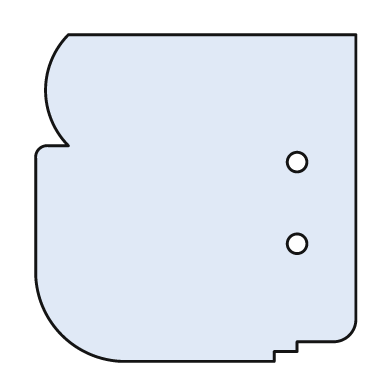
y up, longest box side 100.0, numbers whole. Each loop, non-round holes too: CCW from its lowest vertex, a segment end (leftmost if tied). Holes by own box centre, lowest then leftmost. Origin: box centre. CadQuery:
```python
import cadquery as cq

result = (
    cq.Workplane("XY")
    .moveTo(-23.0, -50.0)
    .lineTo(24.0, -50.0)
    .lineTo(24.0, -47.0)
    .lineTo(31.0, -47.0)
    .lineTo(31.0, -44.0)
    .lineTo(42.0, -44.0)
    .threePointArc((47.0, -42.0), (49.0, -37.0))
    .lineTo(49.0, 50.0)
    .lineTo(-39.0, 50.0)
    .threePointArc((-46.0, 33.0), (-39.0, 16.0))
    .lineTo(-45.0, 16.0)
    .threePointArc((-48.0, 15.0), (-49.0, 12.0))
    .lineTo(-49.0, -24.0)
    .threePointArc((-41.0, -42.0), (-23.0, -50.0))
    .close()
    .moveTo(31.0, -14.0)
    .circle(3.0)
    .moveTo(31.0, 11.0)
    .circle(3.0)
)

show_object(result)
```